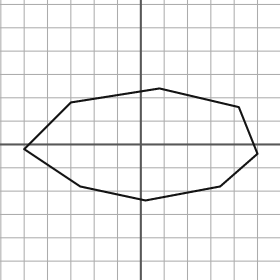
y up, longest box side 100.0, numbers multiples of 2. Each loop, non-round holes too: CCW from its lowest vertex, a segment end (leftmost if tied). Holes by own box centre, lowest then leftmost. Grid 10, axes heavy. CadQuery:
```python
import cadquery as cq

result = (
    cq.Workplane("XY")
    .moveTo(2.0, -24.0)
    .lineTo(34.0, -18.0)
    .lineTo(50.0, -4.0)
    .lineTo(42.0, 16.0)
    .lineTo(8.0, 24.0)
    .lineTo(-30.0, 18.0)
    .lineTo(-50.0, -2.0)
    .lineTo(-26.0, -18.0)
    .close()
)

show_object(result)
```